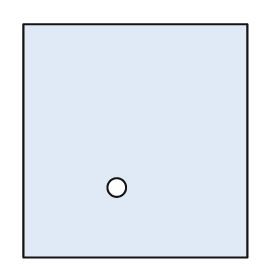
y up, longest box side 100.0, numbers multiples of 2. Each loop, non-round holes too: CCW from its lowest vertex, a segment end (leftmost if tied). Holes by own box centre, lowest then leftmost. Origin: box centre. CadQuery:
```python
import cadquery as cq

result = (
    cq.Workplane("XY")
    .moveTo(-48.0, -50.0)
    .lineTo(48.0, -50.0)
    .lineTo(48.0, 50.0)
    .lineTo(-48.0, 50.0)
    .close()
    .moveTo(-8.0, -20.0)
    .circle(4.0)
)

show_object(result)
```